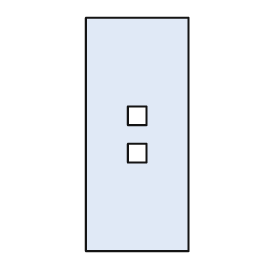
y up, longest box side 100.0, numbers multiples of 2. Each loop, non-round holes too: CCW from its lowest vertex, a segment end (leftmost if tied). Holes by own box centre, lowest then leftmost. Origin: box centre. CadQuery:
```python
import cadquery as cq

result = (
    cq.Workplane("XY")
    .moveTo(-22.0, -50.0)
    .lineTo(22.0, -50.0)
    .lineTo(22.0, 50.0)
    .lineTo(-22.0, 50.0)
    .close()
    .moveTo(-4.0, -12.0)
    .lineTo(4.0, -12.0)
    .lineTo(4.0, -4.0)
    .lineTo(-4.0, -4.0)
    .close()
    .moveTo(-4.0, 4.0)
    .lineTo(4.0, 4.0)
    .lineTo(4.0, 12.0)
    .lineTo(-4.0, 12.0)
    .close()
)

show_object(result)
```